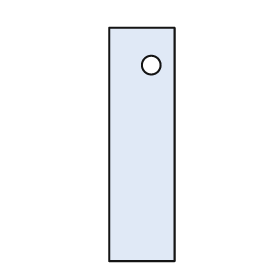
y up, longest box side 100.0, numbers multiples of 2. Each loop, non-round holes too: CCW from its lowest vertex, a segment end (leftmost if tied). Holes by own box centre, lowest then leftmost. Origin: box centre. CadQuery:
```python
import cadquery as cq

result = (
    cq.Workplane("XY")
    .moveTo(-14.0, -50.0)
    .lineTo(14.0, -50.0)
    .lineTo(14.0, 50.0)
    .lineTo(-14.0, 50.0)
    .close()
    .moveTo(4.0, 34.0)
    .circle(4.0)
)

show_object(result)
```